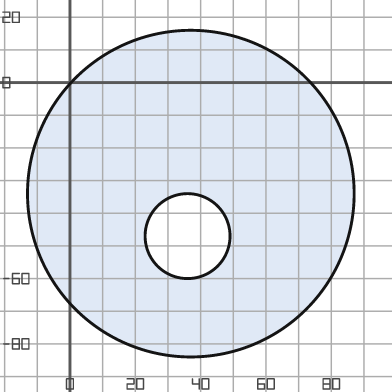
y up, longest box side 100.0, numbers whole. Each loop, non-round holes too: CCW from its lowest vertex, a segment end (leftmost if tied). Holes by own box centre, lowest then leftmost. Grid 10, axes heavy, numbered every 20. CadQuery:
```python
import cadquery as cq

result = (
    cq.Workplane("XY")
    .moveTo(37.0, -34.0)
    .circle(50.0)
    .moveTo(36.0, -47.0)
    .circle(13.0)
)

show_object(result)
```